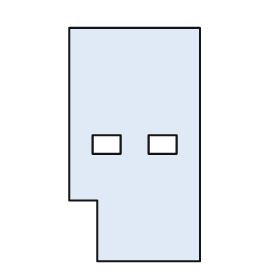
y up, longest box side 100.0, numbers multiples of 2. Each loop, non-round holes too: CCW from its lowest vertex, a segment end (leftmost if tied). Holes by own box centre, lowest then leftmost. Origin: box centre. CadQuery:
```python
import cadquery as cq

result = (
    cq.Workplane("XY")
    .moveTo(-16.0, -50.0)
    .lineTo(28.0, -50.0)
    .lineTo(28.0, 50.0)
    .lineTo(-28.0, 50.0)
    .lineTo(-28.0, -24.0)
    .lineTo(-16.0, -24.0)
    .close()
    .moveTo(-18.0, -4.0)
    .lineTo(-6.0, -4.0)
    .lineTo(-6.0, 4.0)
    .lineTo(-18.0, 4.0)
    .close()
    .moveTo(6.0, -4.0)
    .lineTo(18.0, -4.0)
    .lineTo(18.0, 4.0)
    .lineTo(6.0, 4.0)
    .close()
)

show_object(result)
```